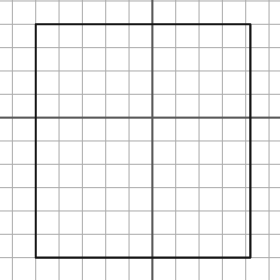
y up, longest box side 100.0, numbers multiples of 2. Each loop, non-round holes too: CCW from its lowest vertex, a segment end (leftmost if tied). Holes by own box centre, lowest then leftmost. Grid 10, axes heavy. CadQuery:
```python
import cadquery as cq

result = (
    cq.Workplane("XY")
    .moveTo(-50.0, -60.0)
    .lineTo(42.0, -60.0)
    .lineTo(42.0, 40.0)
    .lineTo(-50.0, 40.0)
    .close()
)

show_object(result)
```